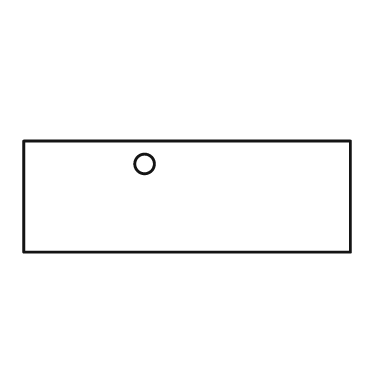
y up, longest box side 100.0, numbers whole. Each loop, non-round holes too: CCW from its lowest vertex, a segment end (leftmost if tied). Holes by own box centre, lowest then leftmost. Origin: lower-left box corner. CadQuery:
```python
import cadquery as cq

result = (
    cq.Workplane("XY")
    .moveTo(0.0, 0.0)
    .lineTo(100.0, 0.0)
    .lineTo(100.0, 34.0)
    .lineTo(0.0, 34.0)
    .close()
    .moveTo(37.0, 27.0)
    .circle(3.0)
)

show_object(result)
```